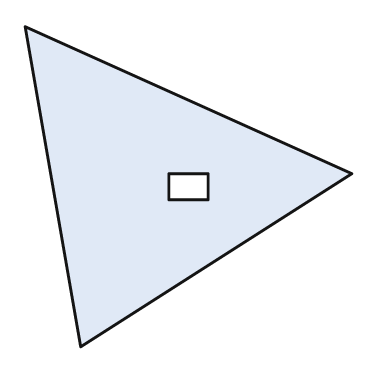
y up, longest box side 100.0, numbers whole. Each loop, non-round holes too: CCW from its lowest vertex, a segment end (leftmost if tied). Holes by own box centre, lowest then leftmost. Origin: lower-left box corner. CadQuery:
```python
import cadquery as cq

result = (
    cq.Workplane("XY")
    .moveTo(17.0, 0.0)
    .lineTo(100.0, 53.0)
    .lineTo(0.0, 98.0)
    .close()
    .moveTo(44.0, 45.0)
    .lineTo(56.0, 45.0)
    .lineTo(56.0, 53.0)
    .lineTo(44.0, 53.0)
    .close()
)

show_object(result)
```